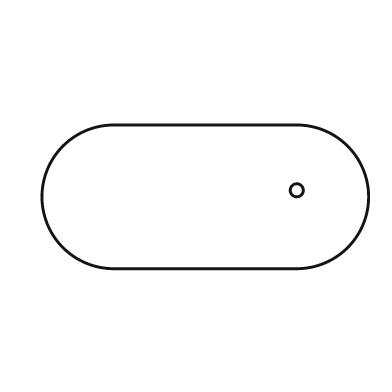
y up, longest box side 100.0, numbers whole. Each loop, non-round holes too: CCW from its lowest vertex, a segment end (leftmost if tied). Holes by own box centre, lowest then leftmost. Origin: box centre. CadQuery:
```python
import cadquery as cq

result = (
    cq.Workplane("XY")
    .moveTo(-28.0, -22.0)
    .lineTo(28.0, -22.0)
    .threePointArc((50.0, 0.0), (28.0, 22.0))
    .lineTo(-28.0, 22.0)
    .threePointArc((-50.0, 0.0), (-28.0, -22.0))
    .close()
    .moveTo(28.0, 2.0)
    .circle(2.0)
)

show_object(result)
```